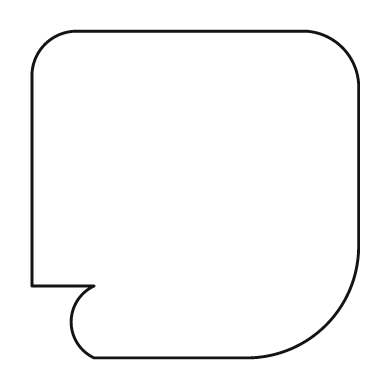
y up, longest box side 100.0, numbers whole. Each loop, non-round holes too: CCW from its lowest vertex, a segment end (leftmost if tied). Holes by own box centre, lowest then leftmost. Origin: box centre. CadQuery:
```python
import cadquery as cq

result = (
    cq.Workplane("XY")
    .moveTo(-31.0, -50.0)
    .lineTo(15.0, -50.0)
    .threePointArc((40.0, -40.0), (50.0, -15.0))
    .lineTo(50.0, 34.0)
    .threePointArc((45.0, 45.0), (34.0, 50.0))
    .lineTo(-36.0, 50.0)
    .threePointArc((-46.0, 46.0), (-50.0, 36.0))
    .lineTo(-50.0, -28.0)
    .lineTo(-31.0, -28.0)
    .threePointArc((-38.0, -39.0), (-31.0, -50.0))
    .close()
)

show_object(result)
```